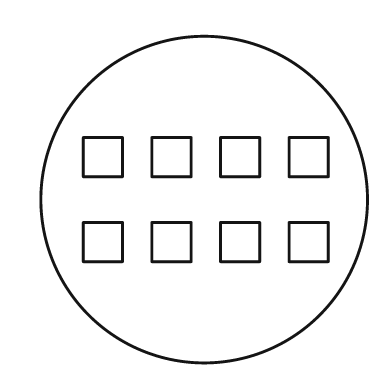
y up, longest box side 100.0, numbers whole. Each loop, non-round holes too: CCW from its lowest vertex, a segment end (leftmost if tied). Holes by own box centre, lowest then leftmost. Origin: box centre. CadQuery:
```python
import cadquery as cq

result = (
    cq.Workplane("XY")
    .moveTo(0.0, 0.0)
    .circle(50.0)
    .moveTo(-37.0, -19.0)
    .lineTo(-25.0, -19.0)
    .lineTo(-25.0, -7.0)
    .lineTo(-37.0, -7.0)
    .close()
    .moveTo(-16.0, -19.0)
    .lineTo(-4.0, -19.0)
    .lineTo(-4.0, -7.0)
    .lineTo(-16.0, -7.0)
    .close()
    .moveTo(5.0, -19.0)
    .lineTo(17.0, -19.0)
    .lineTo(17.0, -7.0)
    .lineTo(5.0, -7.0)
    .close()
    .moveTo(26.0, -19.0)
    .lineTo(38.0, -19.0)
    .lineTo(38.0, -7.0)
    .lineTo(26.0, -7.0)
    .close()
    .moveTo(-37.0, 7.0)
    .lineTo(-25.0, 7.0)
    .lineTo(-25.0, 19.0)
    .lineTo(-37.0, 19.0)
    .close()
    .moveTo(-16.0, 7.0)
    .lineTo(-4.0, 7.0)
    .lineTo(-4.0, 19.0)
    .lineTo(-16.0, 19.0)
    .close()
    .moveTo(5.0, 7.0)
    .lineTo(17.0, 7.0)
    .lineTo(17.0, 19.0)
    .lineTo(5.0, 19.0)
    .close()
    .moveTo(26.0, 7.0)
    .lineTo(38.0, 7.0)
    .lineTo(38.0, 19.0)
    .lineTo(26.0, 19.0)
    .close()
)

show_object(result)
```